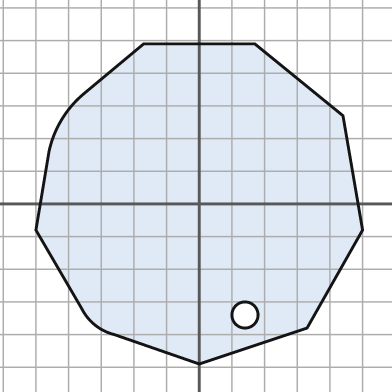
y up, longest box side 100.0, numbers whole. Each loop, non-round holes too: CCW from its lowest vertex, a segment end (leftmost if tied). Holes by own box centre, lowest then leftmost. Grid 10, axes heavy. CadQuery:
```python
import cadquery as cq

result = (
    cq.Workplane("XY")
    .moveTo(0.0, -49.0)
    .lineTo(33.0, -38.0)
    .lineTo(50.0, -8.0)
    .lineTo(44.0, 27.0)
    .lineTo(17.0, 49.0)
    .lineTo(-17.0, 49.0)
    .lineTo(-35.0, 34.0)
    .threePointArc((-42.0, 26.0), (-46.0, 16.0))
    .lineTo(-50.0, -8.0)
    .lineTo(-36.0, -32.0)
    .threePointArc((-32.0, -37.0), (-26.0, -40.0))
    .close()
    .moveTo(14.0, -34.0)
    .circle(4.0)
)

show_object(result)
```